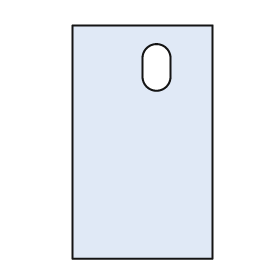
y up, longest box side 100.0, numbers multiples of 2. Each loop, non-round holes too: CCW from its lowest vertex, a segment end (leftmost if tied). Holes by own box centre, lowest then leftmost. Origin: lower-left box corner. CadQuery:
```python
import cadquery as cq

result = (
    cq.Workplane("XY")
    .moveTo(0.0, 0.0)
    .lineTo(60.0, 0.0)
    .lineTo(60.0, 100.0)
    .lineTo(0.0, 100.0)
    .close()
    .moveTo(30.0, 78.0)
    .threePointArc((36.0, 72.0), (42.0, 78.0))
    .lineTo(42.0, 86.0)
    .threePointArc((36.0, 92.0), (30.0, 86.0))
    .close()
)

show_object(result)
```